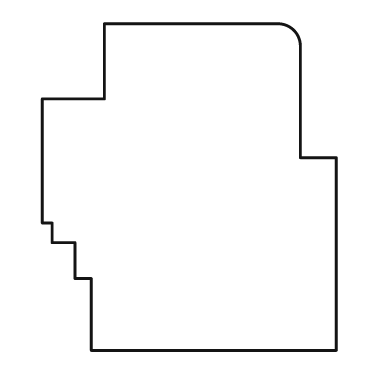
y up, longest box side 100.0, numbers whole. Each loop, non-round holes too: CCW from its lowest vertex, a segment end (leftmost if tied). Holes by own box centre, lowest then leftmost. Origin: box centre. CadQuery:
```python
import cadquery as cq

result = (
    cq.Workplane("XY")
    .moveTo(-30.0, -50.0)
    .lineTo(45.0, -50.0)
    .lineTo(45.0, 9.0)
    .lineTo(34.0, 9.0)
    .lineTo(34.0, 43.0)
    .threePointArc((32.0, 48.0), (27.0, 50.0))
    .lineTo(-26.0, 50.0)
    .lineTo(-26.0, 27.0)
    .lineTo(-45.0, 27.0)
    .lineTo(-45.0, -11.0)
    .lineTo(-42.0, -11.0)
    .lineTo(-42.0, -17.0)
    .lineTo(-35.0, -17.0)
    .lineTo(-35.0, -28.0)
    .lineTo(-30.0, -28.0)
    .close()
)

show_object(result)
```